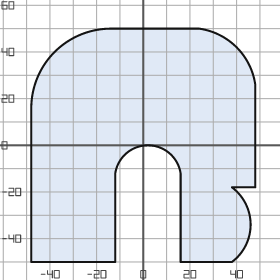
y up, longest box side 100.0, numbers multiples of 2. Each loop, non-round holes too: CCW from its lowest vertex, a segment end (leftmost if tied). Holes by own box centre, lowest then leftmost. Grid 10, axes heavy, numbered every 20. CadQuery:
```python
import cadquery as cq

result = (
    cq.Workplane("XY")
    .moveTo(-48.0, -50.0)
    .lineTo(-12.0, -50.0)
    .lineTo(-12.0, -12.0)
    .threePointArc((2.0, 0.0), (16.0, -12.0))
    .lineTo(16.0, -50.0)
    .lineTo(38.0, -50.0)
    .threePointArc((46.0, -34.0), (38.0, -18.0))
    .lineTo(48.0, -18.0)
    .lineTo(48.0, 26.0)
    .threePointArc((40.0, 42.0), (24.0, 50.0))
    .lineTo(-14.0, 50.0)
    .threePointArc((-38.0, 40.0), (-48.0, 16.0))
    .close()
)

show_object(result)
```